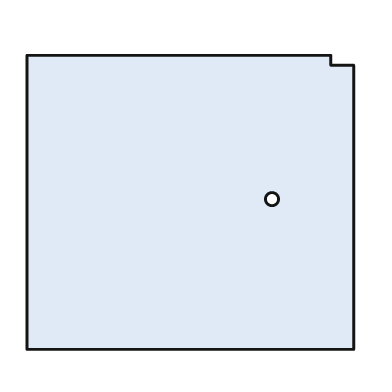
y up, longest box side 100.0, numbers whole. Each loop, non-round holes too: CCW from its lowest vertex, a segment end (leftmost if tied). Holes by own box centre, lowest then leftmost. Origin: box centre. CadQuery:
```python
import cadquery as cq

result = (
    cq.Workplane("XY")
    .moveTo(-50.0, -45.0)
    .lineTo(50.0, -45.0)
    .lineTo(50.0, 42.0)
    .lineTo(43.0, 42.0)
    .lineTo(43.0, 45.0)
    .lineTo(-50.0, 45.0)
    .close()
    .moveTo(25.0, 1.0)
    .circle(2.0)
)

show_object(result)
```